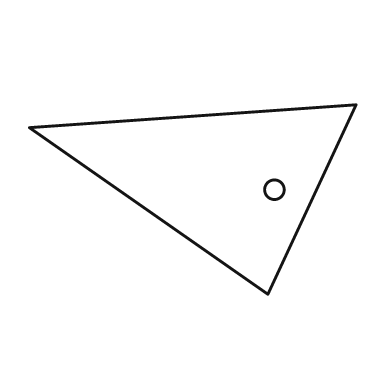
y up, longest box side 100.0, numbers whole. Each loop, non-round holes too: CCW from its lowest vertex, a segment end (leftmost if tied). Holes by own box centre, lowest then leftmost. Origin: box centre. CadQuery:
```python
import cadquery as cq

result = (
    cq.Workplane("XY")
    .moveTo(23.0, -29.0)
    .lineTo(50.0, 29.0)
    .lineTo(-50.0, 22.0)
    .close()
    .moveTo(25.0, 3.0)
    .circle(3.0)
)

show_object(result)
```